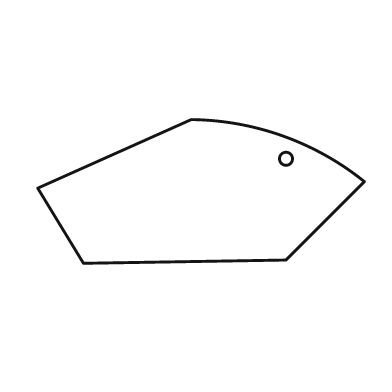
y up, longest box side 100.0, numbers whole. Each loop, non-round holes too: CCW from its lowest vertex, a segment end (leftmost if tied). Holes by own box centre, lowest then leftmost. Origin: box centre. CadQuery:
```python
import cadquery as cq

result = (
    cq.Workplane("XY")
    .moveTo(-36.0, -22.0)
    .lineTo(26.0, -21.0)
    .lineTo(50.0, 3.0)
    .threePointArc((25.0, 17.0), (-3.0, 22.0))
    .lineTo(-50.0, 1.0)
    .close()
    .moveTo(26.0, 10.0)
    .circle(2.0)
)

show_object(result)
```